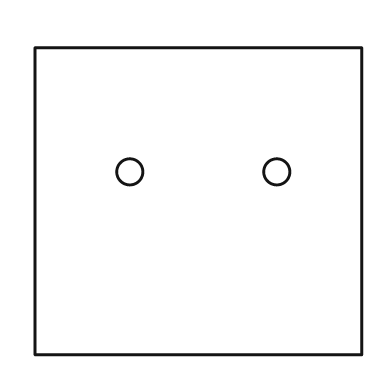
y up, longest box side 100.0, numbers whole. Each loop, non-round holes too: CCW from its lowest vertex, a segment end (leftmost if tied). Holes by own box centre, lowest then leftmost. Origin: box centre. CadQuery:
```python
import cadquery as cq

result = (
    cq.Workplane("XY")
    .moveTo(-50.0, -47.0)
    .lineTo(50.0, -47.0)
    .lineTo(50.0, 47.0)
    .lineTo(-50.0, 47.0)
    .close()
    .moveTo(-21.0, 9.0)
    .circle(4.0)
    .moveTo(24.0, 9.0)
    .circle(4.0)
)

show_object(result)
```